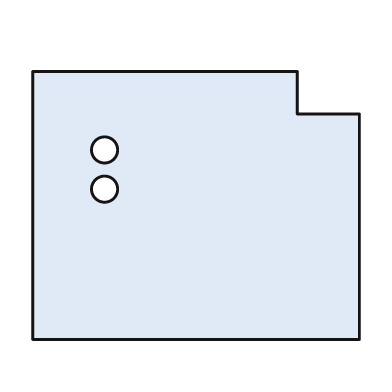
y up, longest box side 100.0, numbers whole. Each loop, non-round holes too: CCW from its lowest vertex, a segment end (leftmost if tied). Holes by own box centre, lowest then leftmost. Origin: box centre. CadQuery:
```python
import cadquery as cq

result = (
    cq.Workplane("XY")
    .moveTo(-50.0, -41.0)
    .lineTo(50.0, -41.0)
    .lineTo(50.0, 28.0)
    .lineTo(31.0, 28.0)
    .lineTo(31.0, 41.0)
    .lineTo(-50.0, 41.0)
    .close()
    .moveTo(-28.0, 5.0)
    .circle(4.0)
    .moveTo(-28.0, 17.0)
    .circle(4.0)
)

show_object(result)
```